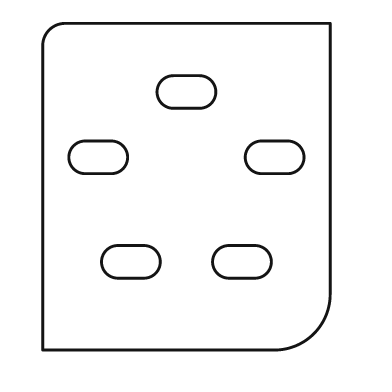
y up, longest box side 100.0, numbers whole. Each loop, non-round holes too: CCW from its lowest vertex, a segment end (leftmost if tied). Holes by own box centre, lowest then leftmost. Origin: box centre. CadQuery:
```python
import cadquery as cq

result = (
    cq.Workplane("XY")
    .moveTo(-44.0, -50.0)
    .lineTo(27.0, -50.0)
    .threePointArc((39.0, -45.0), (44.0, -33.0))
    .lineTo(44.0, 50.0)
    .lineTo(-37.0, 50.0)
    .threePointArc((-42.0, 48.0), (-44.0, 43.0))
    .close()
    .moveTo(-21.0, -28.0)
    .lineTo(-13.0, -28.0)
    .threePointArc((-8.0, -23.0), (-13.0, -18.0))
    .lineTo(-21.0, -18.0)
    .threePointArc((-26.0, -23.0), (-21.0, -28.0))
    .close()
    .moveTo(13.0, -28.0)
    .lineTo(21.0, -28.0)
    .threePointArc((26.0, -23.0), (21.0, -18.0))
    .lineTo(13.0, -18.0)
    .threePointArc((8.0, -23.0), (13.0, -28.0))
    .close()
    .moveTo(-31.0, 4.0)
    .lineTo(-23.0, 4.0)
    .threePointArc((-18.0, 9.0), (-23.0, 14.0))
    .lineTo(-31.0, 14.0)
    .threePointArc((-36.0, 9.0), (-31.0, 4.0))
    .close()
    .moveTo(23.0, 4.0)
    .lineTo(31.0, 4.0)
    .threePointArc((36.0, 9.0), (31.0, 14.0))
    .lineTo(23.0, 14.0)
    .threePointArc((18.0, 9.0), (23.0, 4.0))
    .close()
    .moveTo(-4.0, 24.0)
    .lineTo(4.0, 24.0)
    .threePointArc((9.0, 29.0), (4.0, 34.0))
    .lineTo(-4.0, 34.0)
    .threePointArc((-9.0, 29.0), (-4.0, 24.0))
    .close()
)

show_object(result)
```